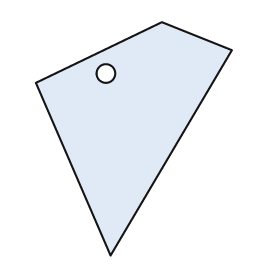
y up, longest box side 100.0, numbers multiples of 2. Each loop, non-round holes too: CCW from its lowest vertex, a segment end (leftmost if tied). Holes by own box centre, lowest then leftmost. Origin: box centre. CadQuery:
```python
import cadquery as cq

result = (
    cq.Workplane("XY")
    .moveTo(-10.0, -50.0)
    .lineTo(42.0, 38.0)
    .lineTo(12.0, 50.0)
    .lineTo(-42.0, 24.0)
    .close()
    .moveTo(-12.0, 28.0)
    .circle(4.0)
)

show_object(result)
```